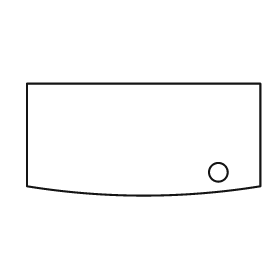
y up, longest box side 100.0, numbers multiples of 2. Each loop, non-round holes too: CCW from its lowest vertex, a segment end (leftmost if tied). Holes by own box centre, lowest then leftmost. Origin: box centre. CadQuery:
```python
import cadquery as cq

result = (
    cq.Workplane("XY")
    .moveTo(-50.0, -20.0)
    .threePointArc((0.0, -24.0), (50.0, -20.0))
    .lineTo(50.0, 24.0)
    .lineTo(-50.0, 24.0)
    .close()
    .moveTo(32.0, -14.0)
    .circle(4.0)
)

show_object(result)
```